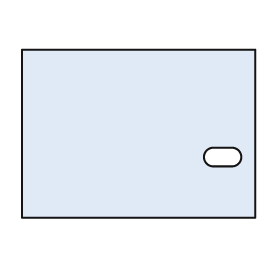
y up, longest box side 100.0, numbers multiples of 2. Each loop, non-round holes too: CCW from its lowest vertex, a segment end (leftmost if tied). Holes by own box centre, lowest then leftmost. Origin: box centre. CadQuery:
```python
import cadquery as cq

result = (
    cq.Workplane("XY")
    .moveTo(-50.0, -36.0)
    .lineTo(50.0, -36.0)
    .lineTo(50.0, 36.0)
    .lineTo(-50.0, 36.0)
    .close()
    .moveTo(32.0, -14.0)
    .lineTo(40.0, -14.0)
    .threePointArc((44.0, -10.0), (40.0, -6.0))
    .lineTo(32.0, -6.0)
    .threePointArc((28.0, -10.0), (32.0, -14.0))
    .close()
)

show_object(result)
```